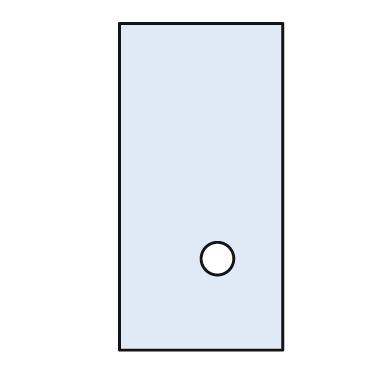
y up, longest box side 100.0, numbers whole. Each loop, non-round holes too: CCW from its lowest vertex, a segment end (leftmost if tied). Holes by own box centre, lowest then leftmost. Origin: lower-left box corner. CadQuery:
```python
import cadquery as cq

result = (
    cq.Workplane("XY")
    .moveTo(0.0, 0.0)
    .lineTo(50.0, 0.0)
    .lineTo(50.0, 100.0)
    .lineTo(0.0, 100.0)
    .close()
    .moveTo(30.0, 28.0)
    .circle(5.0)
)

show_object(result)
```